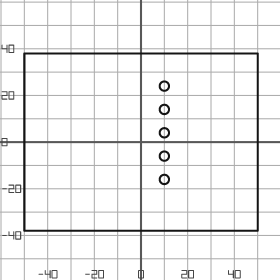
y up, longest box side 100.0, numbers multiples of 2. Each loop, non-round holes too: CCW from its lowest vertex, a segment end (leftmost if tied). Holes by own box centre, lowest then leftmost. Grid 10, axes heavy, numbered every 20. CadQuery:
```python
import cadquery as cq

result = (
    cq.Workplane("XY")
    .moveTo(-50.0, -38.0)
    .lineTo(50.0, -38.0)
    .lineTo(50.0, 38.0)
    .lineTo(-50.0, 38.0)
    .close()
    .moveTo(10.0, -16.0)
    .circle(2.0)
    .moveTo(10.0, -6.0)
    .circle(2.0)
    .moveTo(10.0, 4.0)
    .circle(2.0)
    .moveTo(10.0, 14.0)
    .circle(2.0)
    .moveTo(10.0, 24.0)
    .circle(2.0)
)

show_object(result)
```